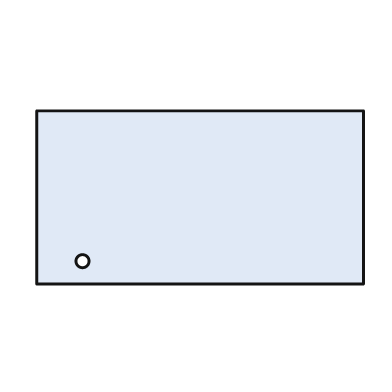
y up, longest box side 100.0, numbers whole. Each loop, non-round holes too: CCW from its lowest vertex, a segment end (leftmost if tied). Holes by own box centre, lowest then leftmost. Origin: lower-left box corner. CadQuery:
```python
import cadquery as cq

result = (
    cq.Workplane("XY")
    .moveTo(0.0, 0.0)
    .lineTo(100.0, 0.0)
    .lineTo(100.0, 53.0)
    .lineTo(0.0, 53.0)
    .close()
    .moveTo(14.0, 7.0)
    .circle(2.0)
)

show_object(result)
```